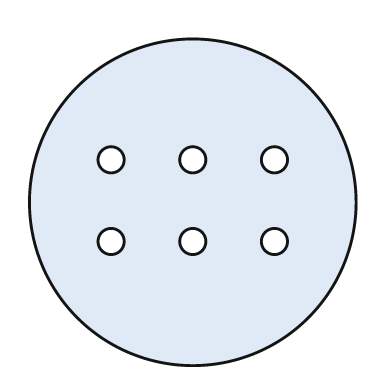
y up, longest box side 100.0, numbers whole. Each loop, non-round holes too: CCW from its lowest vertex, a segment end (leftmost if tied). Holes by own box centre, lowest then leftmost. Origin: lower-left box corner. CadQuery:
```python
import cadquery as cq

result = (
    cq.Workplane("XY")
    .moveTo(50.0, 50.0)
    .circle(50.0)
    .moveTo(25.0, 38.0)
    .circle(4.0)
    .moveTo(50.0, 38.0)
    .circle(4.0)
    .moveTo(75.0, 38.0)
    .circle(4.0)
    .moveTo(25.0, 63.0)
    .circle(4.0)
    .moveTo(50.0, 63.0)
    .circle(4.0)
    .moveTo(75.0, 63.0)
    .circle(4.0)
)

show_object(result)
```